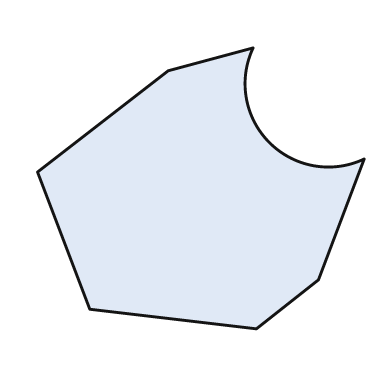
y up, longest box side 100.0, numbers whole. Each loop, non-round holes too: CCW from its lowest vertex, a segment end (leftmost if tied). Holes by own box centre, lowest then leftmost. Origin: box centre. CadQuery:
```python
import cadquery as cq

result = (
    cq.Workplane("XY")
    .moveTo(17.0, -43.0)
    .lineTo(36.0, -28.0)
    .lineTo(50.0, 9.0)
    .threePointArc((21.0, 14.0), (16.0, 43.0))
    .lineTo(-10.0, 36.0)
    .lineTo(-50.0, 5.0)
    .lineTo(-34.0, -37.0)
    .close()
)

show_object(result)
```